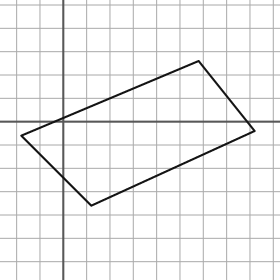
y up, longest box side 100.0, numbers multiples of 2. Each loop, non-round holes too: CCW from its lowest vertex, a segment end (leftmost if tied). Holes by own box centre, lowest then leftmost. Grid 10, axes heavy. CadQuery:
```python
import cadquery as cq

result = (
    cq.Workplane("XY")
    .moveTo(12.0, -36.0)
    .lineTo(82.0, -4.0)
    .lineTo(58.0, 26.0)
    .lineTo(-18.0, -6.0)
    .close()
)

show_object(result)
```